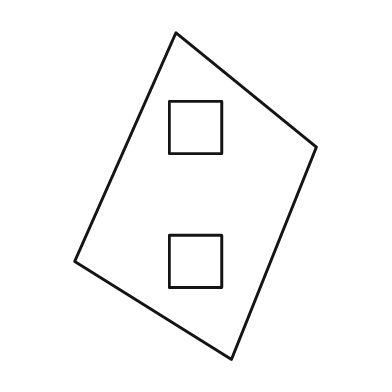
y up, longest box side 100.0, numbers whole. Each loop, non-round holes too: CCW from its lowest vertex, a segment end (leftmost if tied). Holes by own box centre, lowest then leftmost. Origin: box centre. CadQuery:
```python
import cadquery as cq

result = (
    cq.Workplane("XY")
    .moveTo(11.0, -50.0)
    .lineTo(37.0, 15.0)
    .lineTo(-6.0, 50.0)
    .lineTo(-37.0, -20.0)
    .close()
    .moveTo(-8.0, -28.0)
    .lineTo(8.0, -28.0)
    .lineTo(8.0, -12.0)
    .lineTo(-8.0, -12.0)
    .close()
    .moveTo(-8.0, 13.0)
    .lineTo(8.0, 13.0)
    .lineTo(8.0, 29.0)
    .lineTo(-8.0, 29.0)
    .close()
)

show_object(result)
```